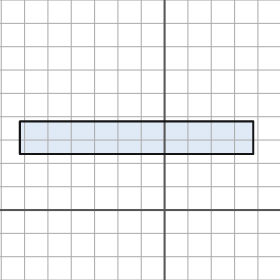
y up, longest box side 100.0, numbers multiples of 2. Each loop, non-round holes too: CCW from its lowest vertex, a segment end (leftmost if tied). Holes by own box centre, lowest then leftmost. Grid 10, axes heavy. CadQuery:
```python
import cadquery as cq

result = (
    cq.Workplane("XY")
    .moveTo(-62.0, 24.0)
    .lineTo(38.0, 24.0)
    .lineTo(38.0, 38.0)
    .lineTo(-62.0, 38.0)
    .close()
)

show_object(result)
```